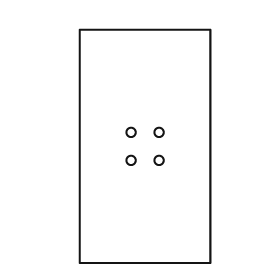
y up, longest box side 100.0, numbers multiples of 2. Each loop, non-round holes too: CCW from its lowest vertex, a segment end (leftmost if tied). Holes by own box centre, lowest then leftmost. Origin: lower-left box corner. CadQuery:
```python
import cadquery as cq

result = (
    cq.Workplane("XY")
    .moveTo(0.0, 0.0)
    .lineTo(56.0, 0.0)
    .lineTo(56.0, 100.0)
    .lineTo(0.0, 100.0)
    .close()
    .moveTo(22.0, 44.0)
    .circle(2.0)
    .moveTo(34.0, 44.0)
    .circle(2.0)
    .moveTo(22.0, 56.0)
    .circle(2.0)
    .moveTo(34.0, 56.0)
    .circle(2.0)
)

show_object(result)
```